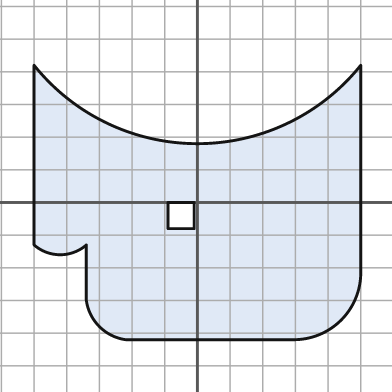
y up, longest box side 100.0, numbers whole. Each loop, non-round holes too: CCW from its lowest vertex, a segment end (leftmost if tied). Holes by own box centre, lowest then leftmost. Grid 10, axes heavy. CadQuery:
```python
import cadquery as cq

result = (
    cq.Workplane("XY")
    .moveTo(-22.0, -42.0)
    .lineTo(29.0, -42.0)
    .threePointArc((44.0, -36.0), (50.0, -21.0))
    .lineTo(50.0, 42.0)
    .threePointArc((0.0, 18.0), (-50.0, 42.0))
    .lineTo(-50.0, -13.0)
    .threePointArc((-42.0, -16.0), (-34.0, -13.0))
    .lineTo(-34.0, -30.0)
    .threePointArc((-30.0, -38.0), (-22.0, -42.0))
    .close()
    .moveTo(-9.0, -8.0)
    .lineTo(-1.0, -8.0)
    .lineTo(-1.0, 0.0)
    .lineTo(-9.0, 0.0)
    .close()
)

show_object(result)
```